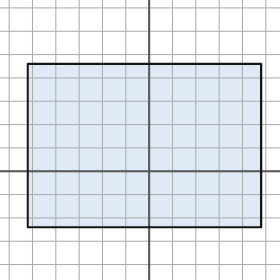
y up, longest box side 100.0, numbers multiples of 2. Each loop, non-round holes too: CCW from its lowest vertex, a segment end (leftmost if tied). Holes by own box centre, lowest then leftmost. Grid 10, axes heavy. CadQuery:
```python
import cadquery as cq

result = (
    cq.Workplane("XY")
    .moveTo(-52.0, -24.0)
    .lineTo(48.0, -24.0)
    .lineTo(48.0, 46.0)
    .lineTo(-52.0, 46.0)
    .close()
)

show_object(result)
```